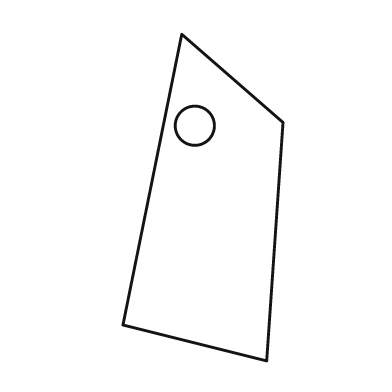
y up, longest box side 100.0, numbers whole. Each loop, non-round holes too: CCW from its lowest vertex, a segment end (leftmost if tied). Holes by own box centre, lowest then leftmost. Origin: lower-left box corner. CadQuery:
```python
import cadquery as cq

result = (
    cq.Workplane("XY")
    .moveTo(44.0, 0.0)
    .lineTo(49.0, 73.0)
    .lineTo(18.0, 100.0)
    .lineTo(0.0, 11.0)
    .close()
    .moveTo(22.0, 72.0)
    .circle(6.0)
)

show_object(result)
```